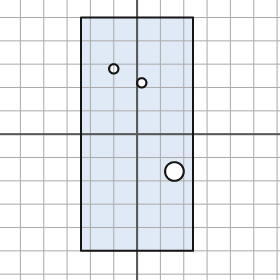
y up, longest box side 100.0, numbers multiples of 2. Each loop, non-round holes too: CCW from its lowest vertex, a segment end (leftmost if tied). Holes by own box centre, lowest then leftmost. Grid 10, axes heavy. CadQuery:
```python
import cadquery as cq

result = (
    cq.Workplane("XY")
    .moveTo(-24.0, -50.0)
    .lineTo(24.0, -50.0)
    .lineTo(24.0, 50.0)
    .lineTo(-24.0, 50.0)
    .close()
    .moveTo(16.0, -16.0)
    .circle(4.0)
    .moveTo(2.0, 22.0)
    .circle(2.0)
    .moveTo(-10.0, 28.0)
    .circle(2.0)
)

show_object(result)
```